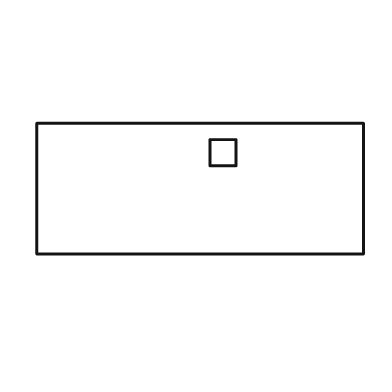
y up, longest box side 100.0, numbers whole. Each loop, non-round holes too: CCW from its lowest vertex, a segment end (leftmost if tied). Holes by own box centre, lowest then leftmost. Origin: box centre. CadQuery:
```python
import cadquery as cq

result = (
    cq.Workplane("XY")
    .moveTo(-50.0, -20.0)
    .lineTo(50.0, -20.0)
    .lineTo(50.0, 20.0)
    .lineTo(-50.0, 20.0)
    .close()
    .moveTo(3.0, 7.0)
    .lineTo(11.0, 7.0)
    .lineTo(11.0, 15.0)
    .lineTo(3.0, 15.0)
    .close()
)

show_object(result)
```